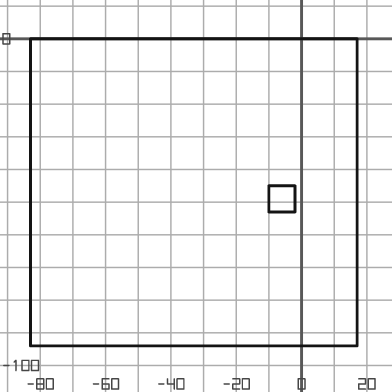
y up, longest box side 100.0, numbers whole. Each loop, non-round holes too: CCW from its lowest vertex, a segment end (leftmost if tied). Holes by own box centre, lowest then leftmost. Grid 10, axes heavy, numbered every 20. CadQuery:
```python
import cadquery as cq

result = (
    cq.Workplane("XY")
    .moveTo(-83.0, -94.0)
    .lineTo(17.0, -94.0)
    .lineTo(17.0, 0.0)
    .lineTo(-83.0, 0.0)
    .close()
    .moveTo(-10.0, -53.0)
    .lineTo(-2.0, -53.0)
    .lineTo(-2.0, -45.0)
    .lineTo(-10.0, -45.0)
    .close()
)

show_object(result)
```